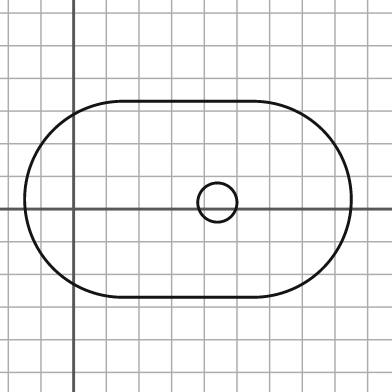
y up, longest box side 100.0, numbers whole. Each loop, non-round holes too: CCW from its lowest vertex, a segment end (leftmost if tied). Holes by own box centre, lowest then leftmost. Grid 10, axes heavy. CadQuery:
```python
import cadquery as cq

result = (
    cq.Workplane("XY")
    .moveTo(15.0, -27.0)
    .lineTo(55.0, -27.0)
    .threePointArc((85.0, 3.0), (55.0, 33.0))
    .lineTo(15.0, 33.0)
    .threePointArc((-15.0, 3.0), (15.0, -27.0))
    .close()
    .moveTo(44.0, 2.0)
    .circle(6.0)
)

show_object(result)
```